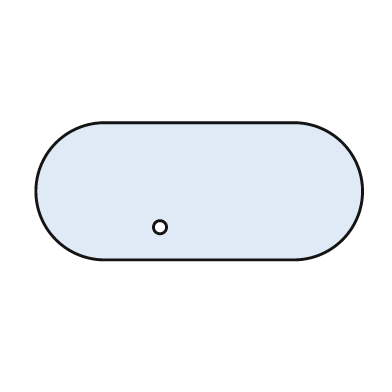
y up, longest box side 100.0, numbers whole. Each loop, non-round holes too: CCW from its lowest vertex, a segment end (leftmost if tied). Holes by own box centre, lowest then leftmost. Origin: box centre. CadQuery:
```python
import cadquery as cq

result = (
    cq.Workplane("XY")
    .moveTo(-29.0, -21.0)
    .lineTo(29.0, -21.0)
    .threePointArc((50.0, 0.0), (29.0, 21.0))
    .lineTo(-29.0, 21.0)
    .threePointArc((-50.0, 0.0), (-29.0, -21.0))
    .close()
    .moveTo(-12.0, -11.0)
    .circle(2.0)
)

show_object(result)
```